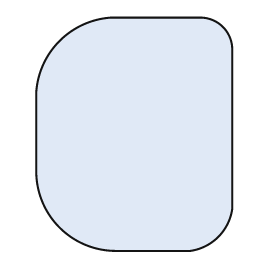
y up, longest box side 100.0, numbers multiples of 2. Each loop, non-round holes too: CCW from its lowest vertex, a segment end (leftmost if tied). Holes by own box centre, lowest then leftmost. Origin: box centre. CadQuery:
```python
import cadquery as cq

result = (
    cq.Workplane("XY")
    .moveTo(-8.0, -50.0)
    .lineTo(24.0, -50.0)
    .threePointArc((36.0, -44.0), (42.0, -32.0))
    .lineTo(42.0, 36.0)
    .threePointArc((38.0, 46.0), (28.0, 50.0))
    .lineTo(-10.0, 50.0)
    .threePointArc((-32.0, 40.0), (-42.0, 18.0))
    .lineTo(-42.0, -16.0)
    .threePointArc((-32.0, -40.0), (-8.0, -50.0))
    .close()
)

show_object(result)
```